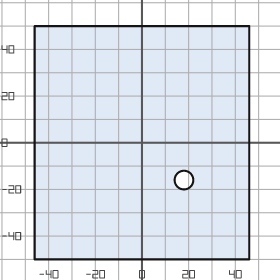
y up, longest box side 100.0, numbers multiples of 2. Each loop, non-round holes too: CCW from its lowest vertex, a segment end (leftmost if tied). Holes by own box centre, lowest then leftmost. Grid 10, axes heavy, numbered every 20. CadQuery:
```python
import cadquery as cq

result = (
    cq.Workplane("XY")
    .moveTo(-46.0, -50.0)
    .lineTo(46.0, -50.0)
    .lineTo(46.0, 50.0)
    .lineTo(-46.0, 50.0)
    .close()
    .moveTo(18.0, -16.0)
    .circle(4.0)
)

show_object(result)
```